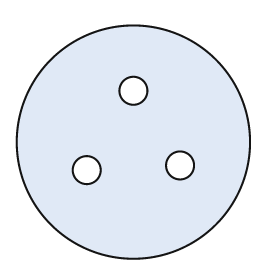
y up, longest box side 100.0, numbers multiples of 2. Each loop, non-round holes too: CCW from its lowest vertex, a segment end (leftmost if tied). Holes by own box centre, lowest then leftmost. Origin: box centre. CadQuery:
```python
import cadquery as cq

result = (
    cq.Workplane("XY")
    .moveTo(0.0, 0.0)
    .circle(50.0)
    .moveTo(-20.0, -12.0)
    .circle(6.0)
    .moveTo(20.0, -10.0)
    .circle(6.0)
    .moveTo(0.0, 22.0)
    .circle(6.0)
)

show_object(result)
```